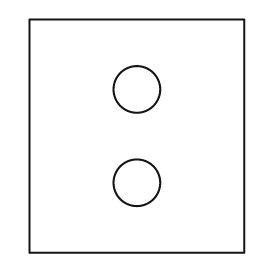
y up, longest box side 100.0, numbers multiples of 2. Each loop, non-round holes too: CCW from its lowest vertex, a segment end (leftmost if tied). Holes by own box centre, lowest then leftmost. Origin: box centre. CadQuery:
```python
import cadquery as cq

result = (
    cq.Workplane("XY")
    .moveTo(-46.0, -50.0)
    .lineTo(46.0, -50.0)
    .lineTo(46.0, 50.0)
    .lineTo(-46.0, 50.0)
    .close()
    .moveTo(0.0, -20.0)
    .circle(10.0)
    .moveTo(0.0, 20.0)
    .circle(10.0)
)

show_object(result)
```